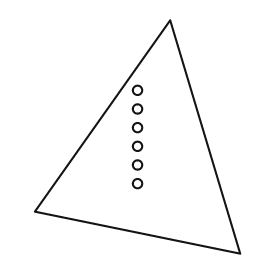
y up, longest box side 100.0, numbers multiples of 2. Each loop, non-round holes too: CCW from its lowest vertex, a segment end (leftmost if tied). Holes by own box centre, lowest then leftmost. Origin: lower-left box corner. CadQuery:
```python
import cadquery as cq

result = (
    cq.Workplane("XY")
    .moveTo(88.0, 0.0)
    .lineTo(58.0, 100.0)
    .lineTo(0.0, 18.0)
    .close()
    .moveTo(44.0, 30.0)
    .circle(2.0)
    .moveTo(44.0, 38.0)
    .circle(2.0)
    .moveTo(44.0, 46.0)
    .circle(2.0)
    .moveTo(44.0, 54.0)
    .circle(2.0)
    .moveTo(44.0, 62.0)
    .circle(2.0)
    .moveTo(44.0, 70.0)
    .circle(2.0)
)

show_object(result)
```